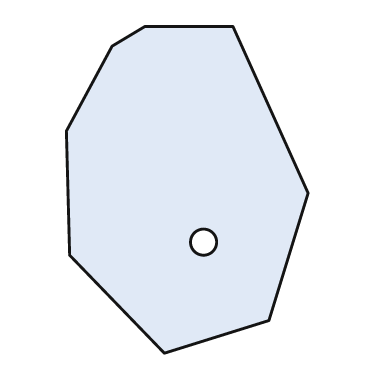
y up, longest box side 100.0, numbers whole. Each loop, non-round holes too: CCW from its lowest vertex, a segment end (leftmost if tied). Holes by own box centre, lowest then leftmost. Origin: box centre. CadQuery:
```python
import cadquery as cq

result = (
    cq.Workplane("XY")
    .moveTo(-7.0, -50.0)
    .lineTo(25.0, -40.0)
    .lineTo(37.0, -1.0)
    .lineTo(14.0, 50.0)
    .lineTo(-13.0, 50.0)
    .lineTo(-23.0, 44.0)
    .lineTo(-37.0, 18.0)
    .lineTo(-36.0, -20.0)
    .close()
    .moveTo(5.0, -16.0)
    .circle(4.0)
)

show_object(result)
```